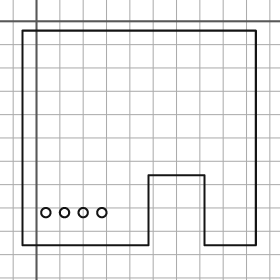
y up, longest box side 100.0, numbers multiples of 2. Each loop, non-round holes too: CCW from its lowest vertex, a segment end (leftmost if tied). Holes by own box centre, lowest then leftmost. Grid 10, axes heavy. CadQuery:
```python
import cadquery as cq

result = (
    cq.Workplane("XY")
    .moveTo(-6.0, -96.0)
    .lineTo(48.0, -96.0)
    .lineTo(48.0, -66.0)
    .lineTo(72.0, -66.0)
    .lineTo(72.0, -96.0)
    .lineTo(94.0, -96.0)
    .lineTo(94.0, -4.0)
    .lineTo(-6.0, -4.0)
    .close()
    .moveTo(4.0, -82.0)
    .circle(2.0)
    .moveTo(12.0, -82.0)
    .circle(2.0)
    .moveTo(20.0, -82.0)
    .circle(2.0)
    .moveTo(28.0, -82.0)
    .circle(2.0)
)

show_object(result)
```